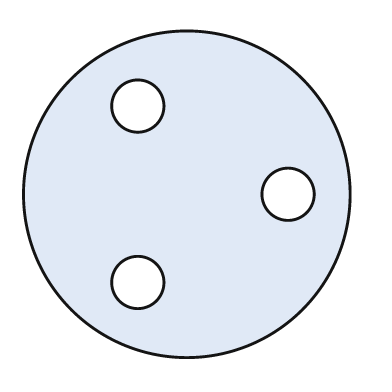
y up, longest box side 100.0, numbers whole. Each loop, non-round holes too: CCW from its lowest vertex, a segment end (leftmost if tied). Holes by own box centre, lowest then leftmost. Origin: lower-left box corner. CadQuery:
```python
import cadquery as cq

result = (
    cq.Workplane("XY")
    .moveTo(50.0, 50.0)
    .circle(50.0)
    .moveTo(35.0, 23.0)
    .circle(8.0)
    .moveTo(81.0, 50.0)
    .circle(8.0)
    .moveTo(35.0, 77.0)
    .circle(8.0)
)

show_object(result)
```